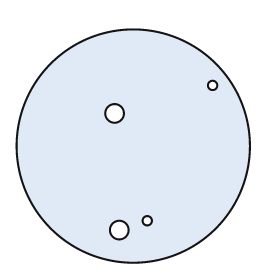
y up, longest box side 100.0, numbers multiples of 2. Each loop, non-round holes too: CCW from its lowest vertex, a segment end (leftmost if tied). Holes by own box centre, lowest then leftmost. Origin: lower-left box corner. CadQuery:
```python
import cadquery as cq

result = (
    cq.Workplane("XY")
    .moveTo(50.0, 50.0)
    .circle(50.0)
    .moveTo(44.0, 14.0)
    .circle(4.0)
    .moveTo(56.0, 18.0)
    .circle(2.0)
    .moveTo(42.0, 64.0)
    .circle(4.0)
    .moveTo(84.0, 76.0)
    .circle(2.0)
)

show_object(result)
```